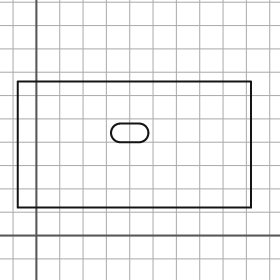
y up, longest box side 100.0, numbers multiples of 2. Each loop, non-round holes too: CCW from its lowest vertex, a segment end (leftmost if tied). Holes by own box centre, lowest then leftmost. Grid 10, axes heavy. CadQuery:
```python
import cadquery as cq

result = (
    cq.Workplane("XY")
    .moveTo(-8.0, 12.0)
    .lineTo(92.0, 12.0)
    .lineTo(92.0, 66.0)
    .lineTo(-8.0, 66.0)
    .close()
    .moveTo(36.0, 40.0)
    .lineTo(44.0, 40.0)
    .threePointArc((48.0, 44.0), (44.0, 48.0))
    .lineTo(36.0, 48.0)
    .threePointArc((32.0, 44.0), (36.0, 40.0))
    .close()
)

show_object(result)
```